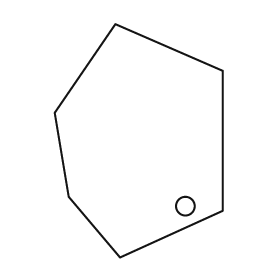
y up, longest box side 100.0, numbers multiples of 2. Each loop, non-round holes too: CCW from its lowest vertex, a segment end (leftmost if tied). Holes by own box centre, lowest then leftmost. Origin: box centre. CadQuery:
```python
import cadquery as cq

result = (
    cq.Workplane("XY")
    .moveTo(-8.0, -50.0)
    .lineTo(36.0, -30.0)
    .lineTo(36.0, 30.0)
    .lineTo(-10.0, 50.0)
    .lineTo(-36.0, 12.0)
    .lineTo(-30.0, -24.0)
    .close()
    .moveTo(20.0, -28.0)
    .circle(4.0)
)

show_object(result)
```